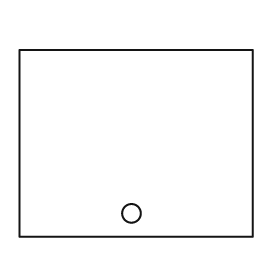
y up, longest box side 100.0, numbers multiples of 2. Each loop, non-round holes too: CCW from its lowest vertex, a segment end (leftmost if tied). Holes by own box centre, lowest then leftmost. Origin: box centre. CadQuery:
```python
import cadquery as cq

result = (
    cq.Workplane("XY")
    .moveTo(-50.0, -40.0)
    .lineTo(50.0, -40.0)
    .lineTo(50.0, 40.0)
    .lineTo(-50.0, 40.0)
    .close()
    .moveTo(-2.0, -30.0)
    .circle(4.0)
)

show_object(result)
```